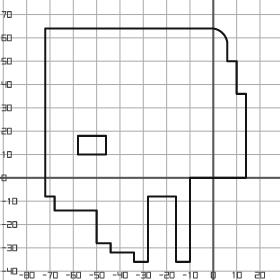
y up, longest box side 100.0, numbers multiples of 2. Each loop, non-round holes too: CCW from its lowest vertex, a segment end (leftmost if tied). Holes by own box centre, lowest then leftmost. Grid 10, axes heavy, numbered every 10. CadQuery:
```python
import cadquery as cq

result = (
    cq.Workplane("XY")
    .moveTo(-34.0, -36.0)
    .lineTo(-28.0, -36.0)
    .lineTo(-28.0, -8.0)
    .lineTo(-16.0, -8.0)
    .lineTo(-16.0, -36.0)
    .lineTo(-10.0, -36.0)
    .lineTo(-10.0, 0.0)
    .lineTo(14.0, 0.0)
    .lineTo(14.0, 36.0)
    .lineTo(10.0, 36.0)
    .lineTo(10.0, 50.0)
    .lineTo(6.0, 50.0)
    .lineTo(6.0, 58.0)
    .threePointArc((4.0, 62.0), (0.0, 64.0))
    .lineTo(-72.0, 64.0)
    .lineTo(-72.0, -8.0)
    .lineTo(-68.0, -8.0)
    .lineTo(-68.0, -14.0)
    .lineTo(-50.0, -14.0)
    .lineTo(-50.0, -28.0)
    .lineTo(-44.0, -28.0)
    .lineTo(-44.0, -32.0)
    .lineTo(-34.0, -32.0)
    .close()
    .moveTo(-58.0, 10.0)
    .lineTo(-46.0, 10.0)
    .lineTo(-46.0, 18.0)
    .lineTo(-58.0, 18.0)
    .close()
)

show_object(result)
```